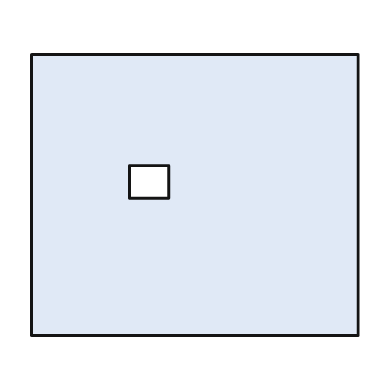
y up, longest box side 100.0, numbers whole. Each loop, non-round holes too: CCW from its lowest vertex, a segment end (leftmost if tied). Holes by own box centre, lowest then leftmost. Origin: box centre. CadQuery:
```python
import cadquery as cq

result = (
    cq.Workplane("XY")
    .moveTo(-50.0, -43.0)
    .lineTo(50.0, -43.0)
    .lineTo(50.0, 43.0)
    .lineTo(-50.0, 43.0)
    .close()
    .moveTo(-20.0, -1.0)
    .lineTo(-8.0, -1.0)
    .lineTo(-8.0, 9.0)
    .lineTo(-20.0, 9.0)
    .close()
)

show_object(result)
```